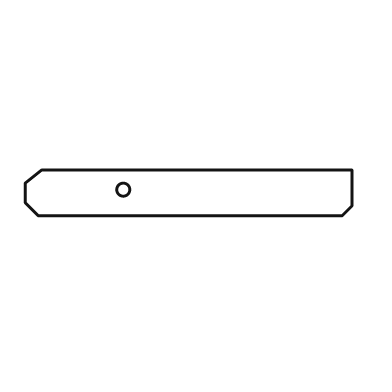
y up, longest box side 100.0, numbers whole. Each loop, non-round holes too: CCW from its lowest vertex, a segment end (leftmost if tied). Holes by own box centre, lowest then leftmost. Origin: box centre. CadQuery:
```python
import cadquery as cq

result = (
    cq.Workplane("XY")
    .moveTo(-46.0, -7.0)
    .lineTo(47.0, -7.0)
    .lineTo(50.0, -4.0)
    .lineTo(50.0, 7.0)
    .lineTo(-45.0, 7.0)
    .lineTo(-50.0, 3.0)
    .lineTo(-50.0, -3.0)
    .close()
    .moveTo(-20.0, 1.0)
    .circle(2.0)
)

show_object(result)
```